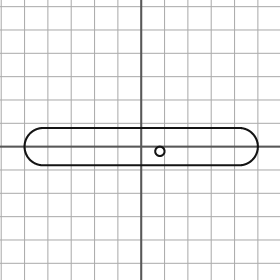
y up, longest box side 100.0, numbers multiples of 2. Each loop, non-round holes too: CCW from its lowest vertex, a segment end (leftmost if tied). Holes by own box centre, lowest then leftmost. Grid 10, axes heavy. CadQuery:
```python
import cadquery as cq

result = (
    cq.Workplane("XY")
    .moveTo(-42.0, -8.0)
    .lineTo(42.0, -8.0)
    .threePointArc((50.0, 0.0), (42.0, 8.0))
    .lineTo(-42.0, 8.0)
    .threePointArc((-50.0, 0.0), (-42.0, -8.0))
    .close()
    .moveTo(8.0, -2.0)
    .circle(2.0)
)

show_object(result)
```